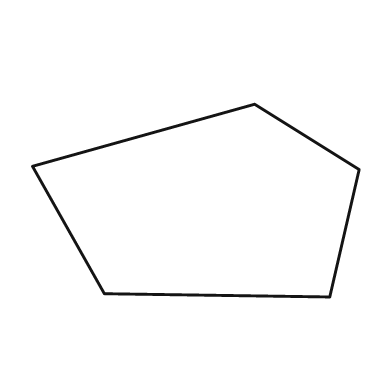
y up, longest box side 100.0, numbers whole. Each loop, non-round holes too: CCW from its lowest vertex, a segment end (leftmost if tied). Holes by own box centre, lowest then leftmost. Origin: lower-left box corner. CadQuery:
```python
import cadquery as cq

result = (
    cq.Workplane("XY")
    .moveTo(91.0, 0.0)
    .lineTo(100.0, 39.0)
    .lineTo(68.0, 59.0)
    .lineTo(0.0, 40.0)
    .lineTo(22.0, 1.0)
    .close()
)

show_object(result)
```